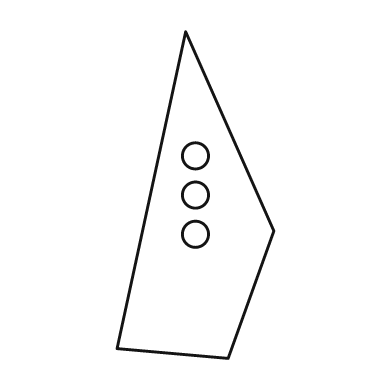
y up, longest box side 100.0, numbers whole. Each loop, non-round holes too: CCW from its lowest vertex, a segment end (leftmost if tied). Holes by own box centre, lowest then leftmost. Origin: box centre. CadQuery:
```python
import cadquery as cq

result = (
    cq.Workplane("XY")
    .moveTo(10.0, -50.0)
    .lineTo(24.0, -11.0)
    .lineTo(-3.0, 50.0)
    .lineTo(-24.0, -47.0)
    .close()
    .moveTo(0.0, -12.0)
    .circle(4.0)
    .moveTo(0.0, 0.0)
    .circle(4.0)
    .moveTo(0.0, 12.0)
    .circle(4.0)
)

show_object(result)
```